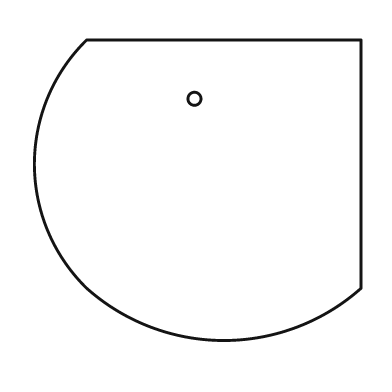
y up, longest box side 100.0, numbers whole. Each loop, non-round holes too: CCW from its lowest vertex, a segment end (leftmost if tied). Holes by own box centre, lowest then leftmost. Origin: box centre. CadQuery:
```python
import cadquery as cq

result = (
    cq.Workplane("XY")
    .moveTo(-34.0, -30.0)
    .threePointArc((8.0, -46.0), (50.0, -30.0))
    .lineTo(50.0, 46.0)
    .lineTo(-34.0, 46.0)
    .threePointArc((-50.0, 8.0), (-34.0, -30.0))
    .close()
    .moveTo(-1.0, 28.0)
    .circle(2.0)
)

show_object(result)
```